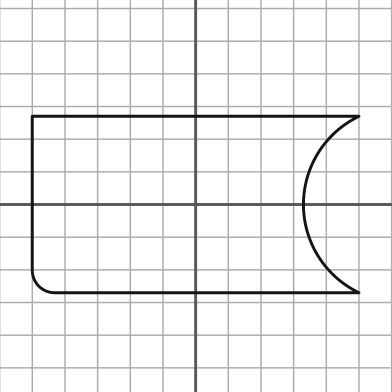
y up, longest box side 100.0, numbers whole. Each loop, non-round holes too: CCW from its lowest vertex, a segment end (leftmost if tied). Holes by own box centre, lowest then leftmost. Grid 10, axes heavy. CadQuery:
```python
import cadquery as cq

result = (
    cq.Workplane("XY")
    .moveTo(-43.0, -27.0)
    .lineTo(50.0, -27.0)
    .threePointArc((33.0, 0.0), (50.0, 27.0))
    .lineTo(-50.0, 27.0)
    .lineTo(-50.0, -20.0)
    .threePointArc((-48.0, -25.0), (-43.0, -27.0))
    .close()
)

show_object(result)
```